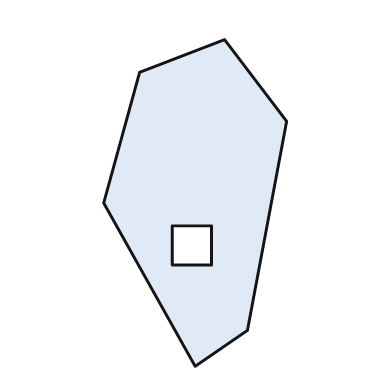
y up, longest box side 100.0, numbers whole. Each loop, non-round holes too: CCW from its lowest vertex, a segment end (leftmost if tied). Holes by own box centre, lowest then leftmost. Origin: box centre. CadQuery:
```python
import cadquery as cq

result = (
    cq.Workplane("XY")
    .moveTo(0.0, -50.0)
    .lineTo(16.0, -39.0)
    .lineTo(28.0, 25.0)
    .lineTo(9.0, 50.0)
    .lineTo(-17.0, 40.0)
    .lineTo(-28.0, 0.0)
    .close()
    .moveTo(-7.0, -19.0)
    .lineTo(5.0, -19.0)
    .lineTo(5.0, -7.0)
    .lineTo(-7.0, -7.0)
    .close()
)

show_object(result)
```